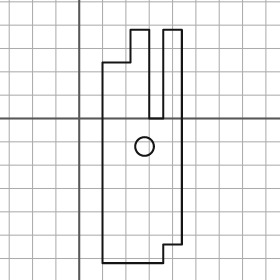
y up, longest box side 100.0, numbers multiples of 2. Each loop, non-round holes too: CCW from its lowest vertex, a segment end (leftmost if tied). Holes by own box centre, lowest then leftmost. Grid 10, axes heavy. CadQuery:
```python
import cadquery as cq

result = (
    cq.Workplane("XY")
    .moveTo(10.0, -62.0)
    .lineTo(36.0, -62.0)
    .lineTo(36.0, -54.0)
    .lineTo(44.0, -54.0)
    .lineTo(44.0, 38.0)
    .lineTo(36.0, 38.0)
    .lineTo(36.0, 0.0)
    .lineTo(30.0, 0.0)
    .lineTo(30.0, 38.0)
    .lineTo(22.0, 38.0)
    .lineTo(22.0, 24.0)
    .lineTo(10.0, 24.0)
    .close()
    .moveTo(28.0, -12.0)
    .circle(4.0)
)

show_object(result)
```